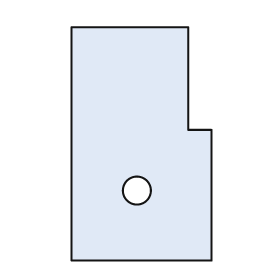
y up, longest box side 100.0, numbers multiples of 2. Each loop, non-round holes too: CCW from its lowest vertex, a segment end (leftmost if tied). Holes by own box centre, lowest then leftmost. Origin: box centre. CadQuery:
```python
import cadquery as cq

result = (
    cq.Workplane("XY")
    .moveTo(-30.0, -50.0)
    .lineTo(30.0, -50.0)
    .lineTo(30.0, 6.0)
    .lineTo(20.0, 6.0)
    .lineTo(20.0, 50.0)
    .lineTo(-30.0, 50.0)
    .close()
    .moveTo(-2.0, -20.0)
    .circle(6.0)
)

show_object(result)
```